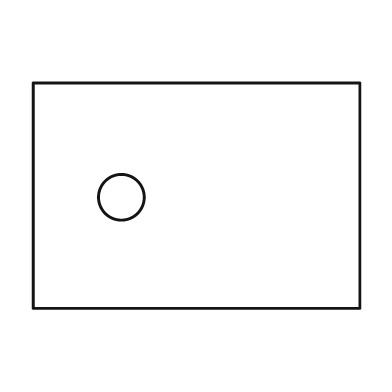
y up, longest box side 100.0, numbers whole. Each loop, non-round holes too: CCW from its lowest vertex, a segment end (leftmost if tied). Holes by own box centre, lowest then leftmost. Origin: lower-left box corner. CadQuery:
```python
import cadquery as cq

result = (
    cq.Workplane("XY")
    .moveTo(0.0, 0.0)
    .lineTo(100.0, 0.0)
    .lineTo(100.0, 69.0)
    .lineTo(0.0, 69.0)
    .close()
    .moveTo(27.0, 34.0)
    .circle(7.0)
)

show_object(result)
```